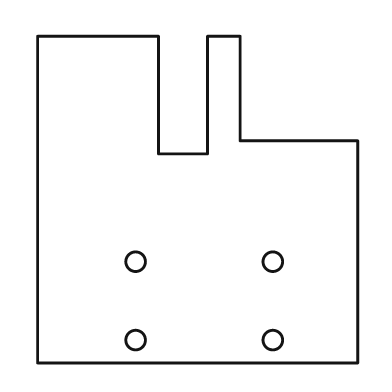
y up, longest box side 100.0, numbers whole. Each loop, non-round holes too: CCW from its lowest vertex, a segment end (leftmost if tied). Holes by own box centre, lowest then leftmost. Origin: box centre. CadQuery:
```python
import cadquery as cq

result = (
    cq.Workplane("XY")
    .moveTo(-49.0, -50.0)
    .lineTo(49.0, -50.0)
    .lineTo(49.0, 18.0)
    .lineTo(13.0, 18.0)
    .lineTo(13.0, 50.0)
    .lineTo(3.0, 50.0)
    .lineTo(3.0, 14.0)
    .lineTo(-12.0, 14.0)
    .lineTo(-12.0, 50.0)
    .lineTo(-49.0, 50.0)
    .close()
    .moveTo(-19.0, -43.0)
    .circle(3.0)
    .moveTo(23.0, -43.0)
    .circle(3.0)
    .moveTo(-19.0, -19.0)
    .circle(3.0)
    .moveTo(23.0, -19.0)
    .circle(3.0)
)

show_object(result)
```